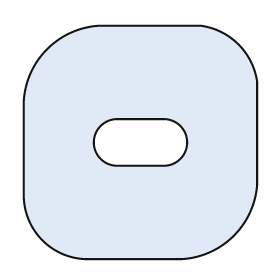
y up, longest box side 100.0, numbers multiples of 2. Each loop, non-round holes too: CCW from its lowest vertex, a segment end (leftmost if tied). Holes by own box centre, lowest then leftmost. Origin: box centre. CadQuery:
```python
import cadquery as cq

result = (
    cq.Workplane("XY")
    .moveTo(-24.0, -50.0)
    .lineTo(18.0, -50.0)
    .threePointArc((40.0, -40.0), (50.0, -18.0))
    .lineTo(50.0, 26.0)
    .threePointArc((42.0, 42.0), (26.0, 50.0))
    .lineTo(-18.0, 50.0)
    .threePointArc((-40.0, 40.0), (-50.0, 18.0))
    .lineTo(-50.0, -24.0)
    .threePointArc((-42.0, -42.0), (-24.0, -50.0))
    .close()
    .moveTo(-10.0, -10.0)
    .lineTo(10.0, -10.0)
    .threePointArc((20.0, 0.0), (10.0, 10.0))
    .lineTo(-10.0, 10.0)
    .threePointArc((-20.0, 0.0), (-10.0, -10.0))
    .close()
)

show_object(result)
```